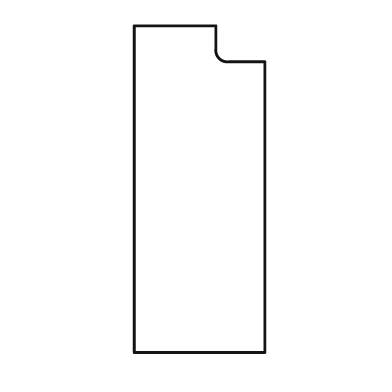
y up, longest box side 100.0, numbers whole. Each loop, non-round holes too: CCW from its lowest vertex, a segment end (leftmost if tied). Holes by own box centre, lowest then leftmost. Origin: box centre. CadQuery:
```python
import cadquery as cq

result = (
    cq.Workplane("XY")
    .moveTo(-20.0, -50.0)
    .lineTo(20.0, -50.0)
    .lineTo(20.0, 39.0)
    .lineTo(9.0, 39.0)
    .threePointArc((6.0, 40.0), (5.0, 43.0))
    .lineTo(5.0, 50.0)
    .lineTo(-20.0, 50.0)
    .close()
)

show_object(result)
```